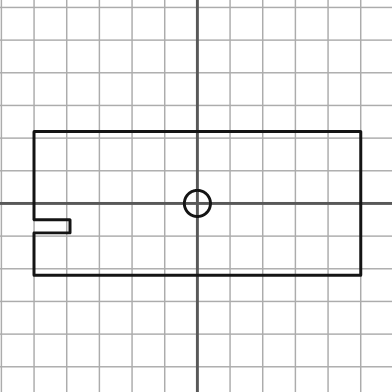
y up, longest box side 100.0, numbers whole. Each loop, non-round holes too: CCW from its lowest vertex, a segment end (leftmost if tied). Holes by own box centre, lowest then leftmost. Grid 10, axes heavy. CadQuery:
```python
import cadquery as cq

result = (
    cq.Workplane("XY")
    .moveTo(-50.0, -22.0)
    .lineTo(50.0, -22.0)
    .lineTo(50.0, 22.0)
    .lineTo(-50.0, 22.0)
    .lineTo(-50.0, -5.0)
    .lineTo(-39.0, -5.0)
    .lineTo(-39.0, -9.0)
    .lineTo(-50.0, -9.0)
    .close()
    .moveTo(0.0, 0.0)
    .circle(4.0)
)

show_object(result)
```